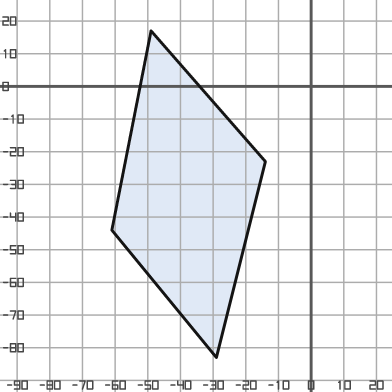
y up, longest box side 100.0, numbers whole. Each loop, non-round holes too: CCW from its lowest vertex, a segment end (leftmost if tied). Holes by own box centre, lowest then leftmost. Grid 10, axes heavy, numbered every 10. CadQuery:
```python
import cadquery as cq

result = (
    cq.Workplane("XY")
    .moveTo(-29.0, -83.0)
    .lineTo(-14.0, -23.0)
    .lineTo(-49.0, 17.0)
    .lineTo(-61.0, -44.0)
    .close()
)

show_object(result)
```